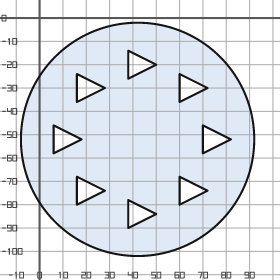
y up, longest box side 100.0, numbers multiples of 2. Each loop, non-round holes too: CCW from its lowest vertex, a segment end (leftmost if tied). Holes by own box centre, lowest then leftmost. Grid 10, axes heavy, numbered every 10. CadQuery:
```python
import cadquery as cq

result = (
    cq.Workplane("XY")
    .moveTo(42.0, -52.0)
    .circle(50.0)
    .moveTo(38.0, -90.0)
    .lineTo(50.0, -84.0)
    .lineTo(38.0, -78.0)
    .close()
    .moveTo(16.0, -80.0)
    .lineTo(28.0, -74.0)
    .lineTo(16.0, -68.0)
    .close()
    .moveTo(60.0, -80.0)
    .lineTo(72.0, -74.0)
    .lineTo(60.0, -68.0)
    .close()
    .moveTo(6.0, -58.0)
    .lineTo(18.0, -52.0)
    .lineTo(6.0, -46.0)
    .close()
    .moveTo(70.0, -58.0)
    .lineTo(82.0, -52.0)
    .lineTo(70.0, -46.0)
    .close()
    .moveTo(16.0, -36.0)
    .lineTo(28.0, -30.0)
    .lineTo(16.0, -24.0)
    .close()
    .moveTo(60.0, -36.0)
    .lineTo(72.0, -30.0)
    .lineTo(60.0, -24.0)
    .close()
    .moveTo(38.0, -26.0)
    .lineTo(50.0, -20.0)
    .lineTo(38.0, -14.0)
    .close()
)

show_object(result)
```